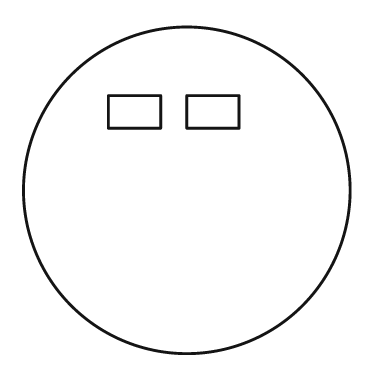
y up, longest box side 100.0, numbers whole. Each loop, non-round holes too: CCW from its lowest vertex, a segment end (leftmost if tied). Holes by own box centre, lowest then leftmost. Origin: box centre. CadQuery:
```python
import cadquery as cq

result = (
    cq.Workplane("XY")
    .moveTo(0.0, 0.0)
    .circle(50.0)
    .moveTo(-24.0, 19.0)
    .lineTo(-8.0, 19.0)
    .lineTo(-8.0, 29.0)
    .lineTo(-24.0, 29.0)
    .close()
    .moveTo(0.0, 19.0)
    .lineTo(16.0, 19.0)
    .lineTo(16.0, 29.0)
    .lineTo(0.0, 29.0)
    .close()
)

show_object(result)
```